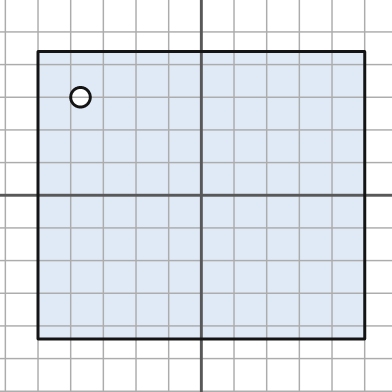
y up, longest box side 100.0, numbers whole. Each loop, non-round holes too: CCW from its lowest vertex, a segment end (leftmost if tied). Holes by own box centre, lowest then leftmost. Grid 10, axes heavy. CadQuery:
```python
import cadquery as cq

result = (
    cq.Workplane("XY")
    .moveTo(-50.0, -44.0)
    .lineTo(50.0, -44.0)
    .lineTo(50.0, 44.0)
    .lineTo(-50.0, 44.0)
    .close()
    .moveTo(-37.0, 30.0)
    .circle(3.0)
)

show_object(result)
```